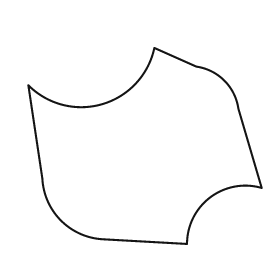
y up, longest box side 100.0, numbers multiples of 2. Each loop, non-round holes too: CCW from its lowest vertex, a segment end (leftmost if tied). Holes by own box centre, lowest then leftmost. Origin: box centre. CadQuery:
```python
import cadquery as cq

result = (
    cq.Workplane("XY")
    .moveTo(18.0, -42.0)
    .threePointArc((28.0, -22.0), (50.0, -18.0))
    .lineTo(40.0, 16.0)
    .threePointArc((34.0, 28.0), (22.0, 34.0))
    .lineTo(4.0, 42.0)
    .threePointArc((-18.0, 18.0), (-50.0, 26.0))
    .lineTo(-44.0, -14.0)
    .threePointArc((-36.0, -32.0), (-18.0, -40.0))
    .close()
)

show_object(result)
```